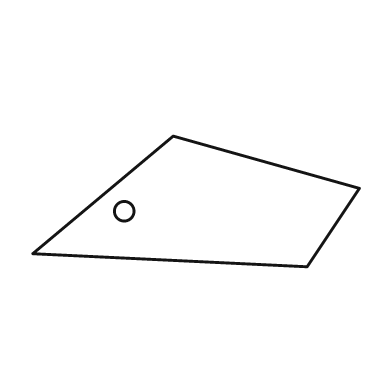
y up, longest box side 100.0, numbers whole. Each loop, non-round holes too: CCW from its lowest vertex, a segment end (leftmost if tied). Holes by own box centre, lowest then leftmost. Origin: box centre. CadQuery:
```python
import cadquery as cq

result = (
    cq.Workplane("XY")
    .moveTo(34.0, -20.0)
    .lineTo(50.0, 4.0)
    .lineTo(-7.0, 20.0)
    .lineTo(-50.0, -16.0)
    .close()
    .moveTo(-22.0, -3.0)
    .circle(3.0)
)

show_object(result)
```